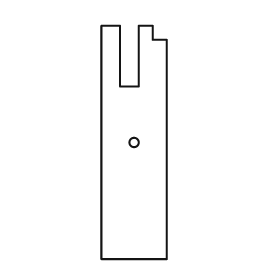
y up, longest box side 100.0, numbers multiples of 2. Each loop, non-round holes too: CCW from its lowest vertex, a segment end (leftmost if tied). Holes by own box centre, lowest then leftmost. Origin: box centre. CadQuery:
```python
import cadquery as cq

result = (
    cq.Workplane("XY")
    .moveTo(-14.0, -50.0)
    .lineTo(14.0, -50.0)
    .lineTo(14.0, 44.0)
    .lineTo(8.0, 44.0)
    .lineTo(8.0, 50.0)
    .lineTo(2.0, 50.0)
    .lineTo(2.0, 24.0)
    .lineTo(-6.0, 24.0)
    .lineTo(-6.0, 50.0)
    .lineTo(-14.0, 50.0)
    .close()
    .moveTo(0.0, 0.0)
    .circle(2.0)
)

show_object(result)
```